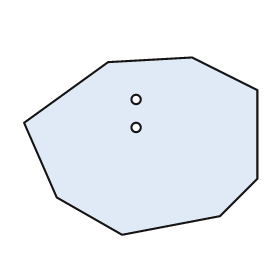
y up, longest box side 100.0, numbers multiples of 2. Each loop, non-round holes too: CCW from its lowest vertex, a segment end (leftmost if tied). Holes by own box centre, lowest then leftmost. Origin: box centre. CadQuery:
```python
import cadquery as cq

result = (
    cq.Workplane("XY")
    .moveTo(-8.0, -38.0)
    .lineTo(34.0, -30.0)
    .lineTo(50.0, -14.0)
    .lineTo(50.0, 24.0)
    .lineTo(22.0, 38.0)
    .lineTo(-14.0, 36.0)
    .lineTo(-50.0, 10.0)
    .lineTo(-36.0, -22.0)
    .close()
    .moveTo(-2.0, 8.0)
    .circle(2.0)
    .moveTo(-2.0, 20.0)
    .circle(2.0)
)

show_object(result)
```